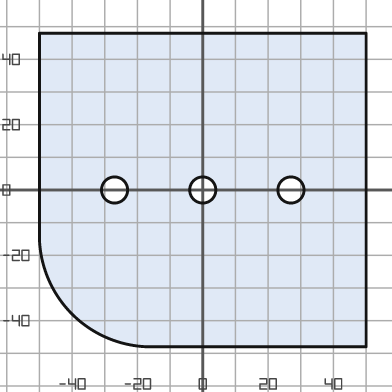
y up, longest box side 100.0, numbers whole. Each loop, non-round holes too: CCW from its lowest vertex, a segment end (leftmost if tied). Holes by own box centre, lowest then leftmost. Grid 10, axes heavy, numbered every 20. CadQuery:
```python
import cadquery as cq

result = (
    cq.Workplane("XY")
    .moveTo(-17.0, -48.0)
    .lineTo(50.0, -48.0)
    .lineTo(50.0, 48.0)
    .lineTo(-50.0, 48.0)
    .lineTo(-50.0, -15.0)
    .threePointArc((-40.0, -38.0), (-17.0, -48.0))
    .close()
    .moveTo(-27.0, 0.0)
    .circle(4.0)
    .moveTo(0.0, 0.0)
    .circle(4.0)
    .moveTo(27.0, 0.0)
    .circle(4.0)
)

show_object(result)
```